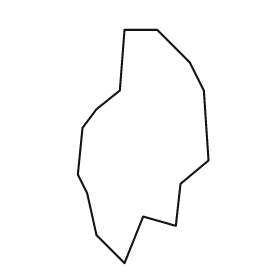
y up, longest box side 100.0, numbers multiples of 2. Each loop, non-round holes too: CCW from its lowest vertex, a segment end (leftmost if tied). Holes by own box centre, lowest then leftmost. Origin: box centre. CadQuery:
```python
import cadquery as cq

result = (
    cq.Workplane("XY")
    .moveTo(-8.0, -50.0)
    .lineTo(0.0, -30.0)
    .lineTo(14.0, -34.0)
    .lineTo(16.0, -16.0)
    .lineTo(28.0, -6.0)
    .lineTo(26.0, 24.0)
    .lineTo(20.0, 36.0)
    .lineTo(6.0, 50.0)
    .lineTo(-8.0, 50.0)
    .lineTo(-10.0, 24.0)
    .lineTo(-20.0, 16.0)
    .lineTo(-26.0, 8.0)
    .lineTo(-28.0, -12.0)
    .lineTo(-24.0, -20.0)
    .lineTo(-20.0, -38.0)
    .close()
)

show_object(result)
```